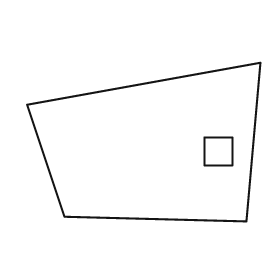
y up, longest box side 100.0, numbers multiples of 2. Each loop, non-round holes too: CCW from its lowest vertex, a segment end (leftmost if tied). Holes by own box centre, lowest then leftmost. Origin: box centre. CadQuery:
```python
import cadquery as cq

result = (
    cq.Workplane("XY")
    .moveTo(44.0, -34.0)
    .lineTo(50.0, 34.0)
    .lineTo(-50.0, 16.0)
    .lineTo(-34.0, -32.0)
    .close()
    .moveTo(26.0, -10.0)
    .lineTo(38.0, -10.0)
    .lineTo(38.0, 2.0)
    .lineTo(26.0, 2.0)
    .close()
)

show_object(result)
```